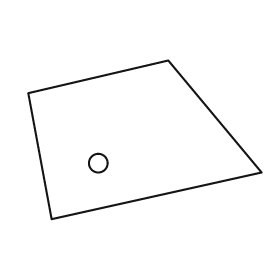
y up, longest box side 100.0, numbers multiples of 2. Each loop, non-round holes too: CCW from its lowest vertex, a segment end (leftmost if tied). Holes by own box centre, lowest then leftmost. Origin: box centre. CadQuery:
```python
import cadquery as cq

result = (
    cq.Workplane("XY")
    .moveTo(-40.0, -34.0)
    .lineTo(50.0, -14.0)
    .lineTo(10.0, 34.0)
    .lineTo(-50.0, 20.0)
    .close()
    .moveTo(-20.0, -10.0)
    .circle(4.0)
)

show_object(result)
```